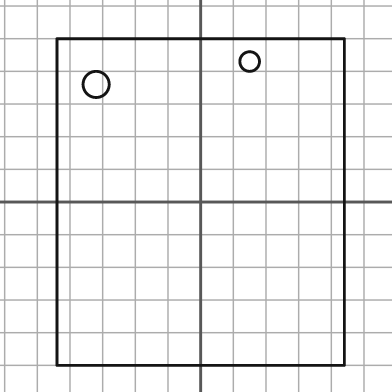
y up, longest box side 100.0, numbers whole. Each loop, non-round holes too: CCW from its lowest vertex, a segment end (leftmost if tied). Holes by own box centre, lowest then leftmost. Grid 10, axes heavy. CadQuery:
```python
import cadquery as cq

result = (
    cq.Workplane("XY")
    .moveTo(-44.0, -50.0)
    .lineTo(44.0, -50.0)
    .lineTo(44.0, 50.0)
    .lineTo(-44.0, 50.0)
    .close()
    .moveTo(-32.0, 36.0)
    .circle(4.0)
    .moveTo(15.0, 43.0)
    .circle(3.0)
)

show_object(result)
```